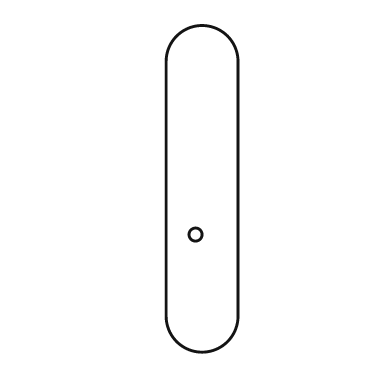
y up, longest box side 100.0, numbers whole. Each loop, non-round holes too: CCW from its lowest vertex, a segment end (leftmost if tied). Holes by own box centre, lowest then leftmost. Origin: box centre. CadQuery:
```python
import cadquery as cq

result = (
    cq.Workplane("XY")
    .moveTo(-11.0, -39.0)
    .threePointArc((0.0, -50.0), (11.0, -39.0))
    .lineTo(11.0, 39.0)
    .threePointArc((0.0, 50.0), (-11.0, 39.0))
    .close()
    .moveTo(-2.0, -14.0)
    .circle(2.0)
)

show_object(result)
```